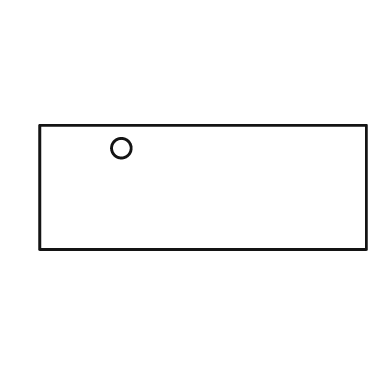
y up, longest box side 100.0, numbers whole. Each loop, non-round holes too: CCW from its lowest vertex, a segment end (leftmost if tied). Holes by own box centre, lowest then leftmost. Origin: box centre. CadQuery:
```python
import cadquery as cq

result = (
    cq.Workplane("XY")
    .moveTo(-50.0, -19.0)
    .lineTo(50.0, -19.0)
    .lineTo(50.0, 19.0)
    .lineTo(-50.0, 19.0)
    .close()
    .moveTo(-25.0, 12.0)
    .circle(3.0)
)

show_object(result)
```